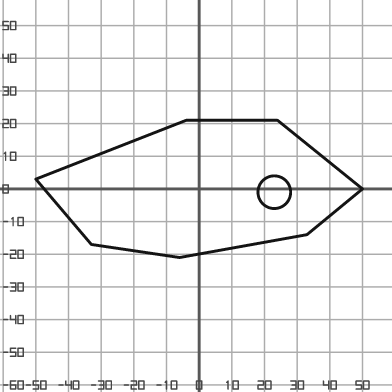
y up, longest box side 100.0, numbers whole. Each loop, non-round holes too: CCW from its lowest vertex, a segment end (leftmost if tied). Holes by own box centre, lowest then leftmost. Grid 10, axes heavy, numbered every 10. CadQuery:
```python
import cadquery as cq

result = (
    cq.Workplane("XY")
    .moveTo(-6.0, -21.0)
    .lineTo(33.0, -14.0)
    .lineTo(50.0, 0.0)
    .lineTo(24.0, 21.0)
    .lineTo(-4.0, 21.0)
    .lineTo(-50.0, 3.0)
    .lineTo(-33.0, -17.0)
    .close()
    .moveTo(23.0, -1.0)
    .circle(5.0)
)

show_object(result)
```